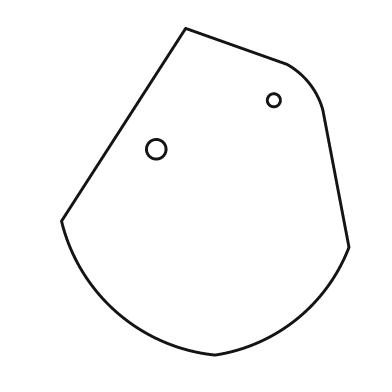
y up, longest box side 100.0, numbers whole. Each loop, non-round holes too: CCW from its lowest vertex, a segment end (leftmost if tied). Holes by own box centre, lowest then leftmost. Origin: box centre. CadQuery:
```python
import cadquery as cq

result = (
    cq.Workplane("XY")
    .moveTo(3.0, -50.0)
    .threePointArc((28.0, -39.0), (44.0, -17.0))
    .lineTo(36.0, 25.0)
    .threePointArc((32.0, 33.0), (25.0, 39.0))
    .lineTo(-6.0, 50.0)
    .lineTo(-44.0, -9.0)
    .threePointArc((-27.0, -37.0), (3.0, -50.0))
    .close()
    .moveTo(-15.0, 13.0)
    .circle(3.0)
    .moveTo(21.0, 28.0)
    .circle(2.0)
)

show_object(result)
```